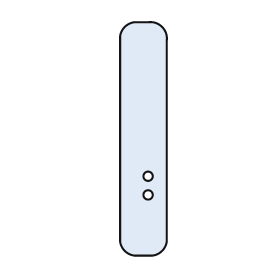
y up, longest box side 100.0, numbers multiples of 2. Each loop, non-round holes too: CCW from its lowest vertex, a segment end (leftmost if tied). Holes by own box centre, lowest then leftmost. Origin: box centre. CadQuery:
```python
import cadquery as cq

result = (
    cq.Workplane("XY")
    .moveTo(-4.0, -50.0)
    .lineTo(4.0, -50.0)
    .threePointArc((8.0, -48.0), (10.0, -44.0))
    .lineTo(10.0, 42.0)
    .threePointArc((8.0, 48.0), (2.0, 50.0))
    .lineTo(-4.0, 50.0)
    .threePointArc((-8.0, 48.0), (-10.0, 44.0))
    .lineTo(-10.0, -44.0)
    .threePointArc((-8.0, -48.0), (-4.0, -50.0))
    .close()
    .moveTo(2.0, -24.0)
    .circle(2.0)
    .moveTo(2.0, -16.0)
    .circle(2.0)
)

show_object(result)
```